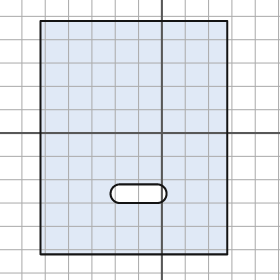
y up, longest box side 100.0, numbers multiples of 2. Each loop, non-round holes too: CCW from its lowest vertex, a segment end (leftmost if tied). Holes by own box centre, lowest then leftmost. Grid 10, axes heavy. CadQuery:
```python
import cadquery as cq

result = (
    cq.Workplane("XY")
    .moveTo(-52.0, -52.0)
    .lineTo(28.0, -52.0)
    .lineTo(28.0, 48.0)
    .lineTo(-52.0, 48.0)
    .close()
    .moveTo(-18.0, -30.0)
    .lineTo(-2.0, -30.0)
    .threePointArc((2.0, -26.0), (-2.0, -22.0))
    .lineTo(-18.0, -22.0)
    .threePointArc((-22.0, -26.0), (-18.0, -30.0))
    .close()
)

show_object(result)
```